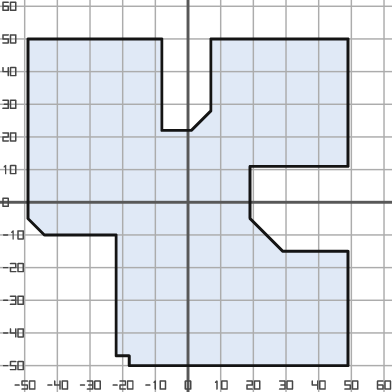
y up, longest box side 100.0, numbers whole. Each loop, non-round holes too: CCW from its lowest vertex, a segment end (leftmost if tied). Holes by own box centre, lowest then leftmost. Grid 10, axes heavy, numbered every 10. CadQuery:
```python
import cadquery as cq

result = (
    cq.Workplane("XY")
    .moveTo(-18.0, -50.0)
    .lineTo(49.0, -50.0)
    .lineTo(49.0, -15.0)
    .lineTo(29.0, -15.0)
    .lineTo(19.0, -5.0)
    .lineTo(19.0, 11.0)
    .lineTo(49.0, 11.0)
    .lineTo(49.0, 50.0)
    .lineTo(7.0, 50.0)
    .lineTo(7.0, 28.0)
    .lineTo(1.0, 22.0)
    .lineTo(-8.0, 22.0)
    .lineTo(-8.0, 50.0)
    .lineTo(-49.0, 50.0)
    .lineTo(-49.0, -5.0)
    .lineTo(-44.0, -10.0)
    .lineTo(-22.0, -10.0)
    .lineTo(-22.0, -47.0)
    .lineTo(-18.0, -47.0)
    .close()
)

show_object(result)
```